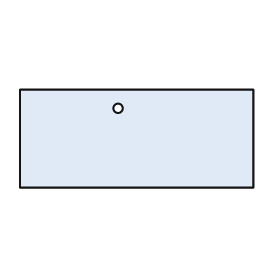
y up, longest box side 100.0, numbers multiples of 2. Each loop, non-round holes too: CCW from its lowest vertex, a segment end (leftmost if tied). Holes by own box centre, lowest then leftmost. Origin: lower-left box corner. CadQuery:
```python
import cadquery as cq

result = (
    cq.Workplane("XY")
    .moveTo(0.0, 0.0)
    .lineTo(100.0, 0.0)
    .lineTo(100.0, 42.0)
    .lineTo(0.0, 42.0)
    .close()
    .moveTo(42.0, 34.0)
    .circle(2.0)
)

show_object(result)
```